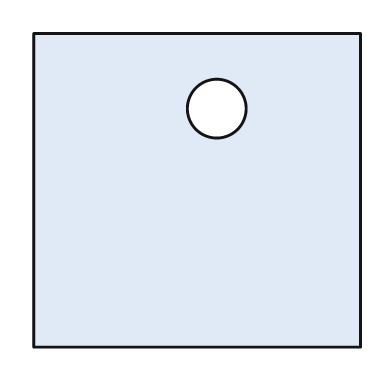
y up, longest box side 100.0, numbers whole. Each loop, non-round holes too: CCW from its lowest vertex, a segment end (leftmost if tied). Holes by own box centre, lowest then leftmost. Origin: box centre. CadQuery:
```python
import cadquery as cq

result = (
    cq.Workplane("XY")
    .moveTo(-50.0, -48.0)
    .lineTo(50.0, -48.0)
    .lineTo(50.0, 48.0)
    .lineTo(-50.0, 48.0)
    .close()
    .moveTo(6.0, 25.0)
    .circle(9.0)
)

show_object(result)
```